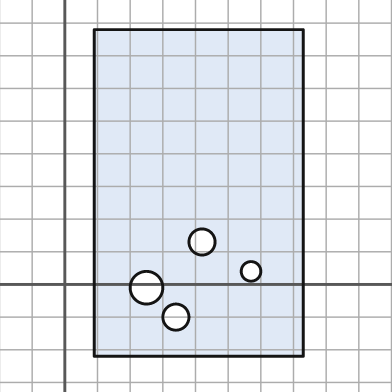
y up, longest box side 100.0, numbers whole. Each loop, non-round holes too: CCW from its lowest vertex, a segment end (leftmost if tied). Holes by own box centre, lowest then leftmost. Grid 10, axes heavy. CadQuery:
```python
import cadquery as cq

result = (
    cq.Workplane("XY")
    .moveTo(9.0, -22.0)
    .lineTo(73.0, -22.0)
    .lineTo(73.0, 78.0)
    .lineTo(9.0, 78.0)
    .close()
    .moveTo(34.0, -10.0)
    .circle(4.0)
    .moveTo(25.0, -1.0)
    .circle(5.0)
    .moveTo(57.0, 4.0)
    .circle(3.0)
    .moveTo(42.0, 13.0)
    .circle(4.0)
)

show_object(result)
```